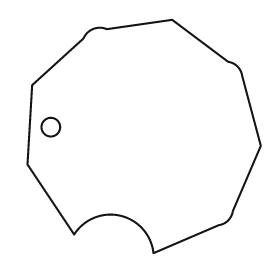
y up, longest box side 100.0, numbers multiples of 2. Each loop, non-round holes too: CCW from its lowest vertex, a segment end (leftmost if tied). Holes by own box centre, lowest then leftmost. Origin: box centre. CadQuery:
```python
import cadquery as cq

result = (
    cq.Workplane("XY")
    .moveTo(4.0, -50.0)
    .lineTo(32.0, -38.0)
    .threePointArc((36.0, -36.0), (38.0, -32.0))
    .lineTo(50.0, -4.0)
    .lineTo(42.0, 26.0)
    .threePointArc((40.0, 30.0), (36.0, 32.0))
    .lineTo(12.0, 50.0)
    .lineTo(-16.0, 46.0)
    .threePointArc((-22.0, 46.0), (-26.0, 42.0))
    .lineTo(-48.0, 22.0)
    .lineTo(-50.0, -12.0)
    .lineTo(-30.0, -42.0)
    .threePointArc((-10.0, -34.0), (4.0, -50.0))
    .close()
    .moveTo(-40.0, 4.0)
    .circle(4.0)
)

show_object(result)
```